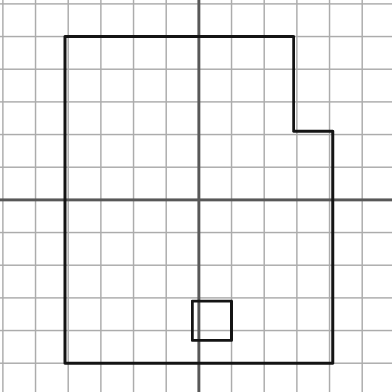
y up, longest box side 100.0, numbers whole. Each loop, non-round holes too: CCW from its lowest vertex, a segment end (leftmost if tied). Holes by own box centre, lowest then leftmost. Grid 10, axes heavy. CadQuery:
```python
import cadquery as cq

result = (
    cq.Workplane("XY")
    .moveTo(-41.0, -50.0)
    .lineTo(41.0, -50.0)
    .lineTo(41.0, 21.0)
    .lineTo(29.0, 21.0)
    .lineTo(29.0, 50.0)
    .lineTo(-41.0, 50.0)
    .close()
    .moveTo(-2.0, -43.0)
    .lineTo(10.0, -43.0)
    .lineTo(10.0, -31.0)
    .lineTo(-2.0, -31.0)
    .close()
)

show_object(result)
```